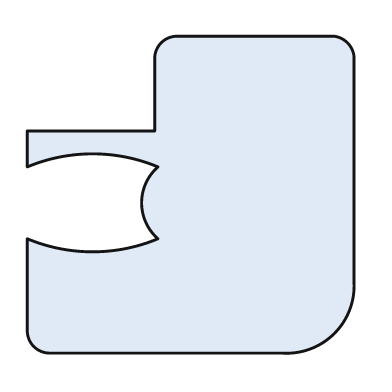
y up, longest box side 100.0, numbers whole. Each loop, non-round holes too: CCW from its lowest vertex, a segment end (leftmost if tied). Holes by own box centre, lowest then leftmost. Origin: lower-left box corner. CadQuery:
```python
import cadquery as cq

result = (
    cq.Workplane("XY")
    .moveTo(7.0, 0.0)
    .lineTo(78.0, 0.0)
    .threePointArc((94.0, 6.0), (100.0, 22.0))
    .lineTo(100.0, 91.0)
    .threePointArc((98.0, 95.0), (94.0, 97.0))
    .lineTo(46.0, 97.0)
    .threePointArc((41.0, 95.0), (39.0, 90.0))
    .lineTo(39.0, 68.0)
    .lineTo(0.0, 68.0)
    .lineTo(0.0, 57.0)
    .threePointArc((20.0, 61.0), (40.0, 57.0))
    .threePointArc((35.0, 46.0), (40.0, 35.0))
    .threePointArc((20.0, 31.0), (0.0, 35.0))
    .lineTo(0.0, 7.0)
    .threePointArc((2.0, 2.0), (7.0, 0.0))
    .close()
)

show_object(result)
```